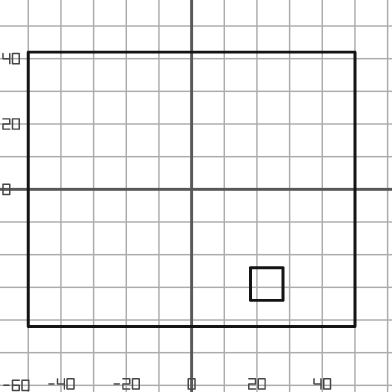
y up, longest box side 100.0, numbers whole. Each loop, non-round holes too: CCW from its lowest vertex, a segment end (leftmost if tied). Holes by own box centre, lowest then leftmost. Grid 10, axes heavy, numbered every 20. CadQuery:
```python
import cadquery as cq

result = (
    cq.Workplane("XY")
    .moveTo(-50.0, -42.0)
    .lineTo(50.0, -42.0)
    .lineTo(50.0, 42.0)
    .lineTo(-50.0, 42.0)
    .close()
    .moveTo(18.0, -34.0)
    .lineTo(28.0, -34.0)
    .lineTo(28.0, -24.0)
    .lineTo(18.0, -24.0)
    .close()
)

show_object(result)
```